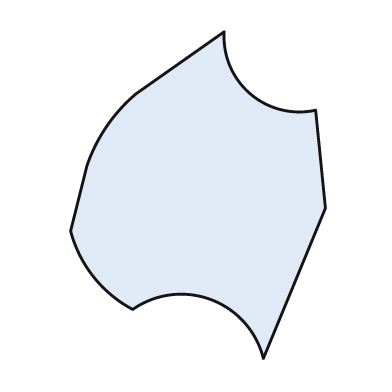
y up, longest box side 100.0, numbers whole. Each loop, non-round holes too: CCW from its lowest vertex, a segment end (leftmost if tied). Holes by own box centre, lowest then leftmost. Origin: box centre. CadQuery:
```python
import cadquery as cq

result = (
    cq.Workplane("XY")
    .moveTo(20.0, -50.0)
    .lineTo(39.0, -4.0)
    .lineTo(36.0, 26.0)
    .threePointArc((16.0, 31.0), (8.0, 50.0))
    .lineTo(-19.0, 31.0)
    .threePointArc((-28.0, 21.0), (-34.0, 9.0))
    .lineTo(-39.0, -11.0)
    .threePointArc((-32.0, -25.0), (-20.0, -35.0))
    .threePointArc((4.0, -32.0), (20.0, -50.0))
    .close()
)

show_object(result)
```